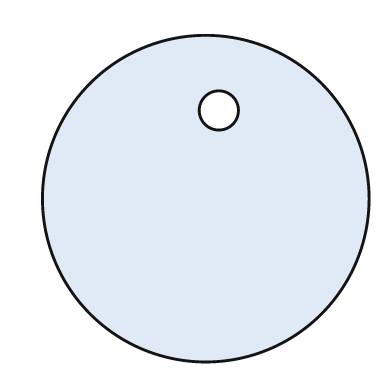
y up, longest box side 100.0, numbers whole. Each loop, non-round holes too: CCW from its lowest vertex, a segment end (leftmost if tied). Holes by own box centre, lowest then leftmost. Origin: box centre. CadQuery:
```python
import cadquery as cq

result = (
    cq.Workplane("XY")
    .moveTo(0.0, 0.0)
    .circle(50.0)
    .moveTo(4.0, 27.0)
    .circle(6.0)
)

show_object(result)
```